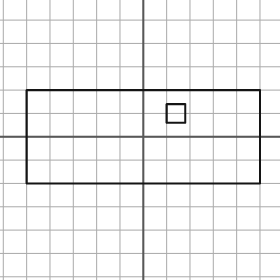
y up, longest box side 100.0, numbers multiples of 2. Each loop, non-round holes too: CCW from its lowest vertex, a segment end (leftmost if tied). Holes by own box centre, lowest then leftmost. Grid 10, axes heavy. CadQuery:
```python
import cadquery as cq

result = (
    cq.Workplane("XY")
    .moveTo(-50.0, -20.0)
    .lineTo(50.0, -20.0)
    .lineTo(50.0, 20.0)
    .lineTo(-50.0, 20.0)
    .close()
    .moveTo(10.0, 6.0)
    .lineTo(18.0, 6.0)
    .lineTo(18.0, 14.0)
    .lineTo(10.0, 14.0)
    .close()
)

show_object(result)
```